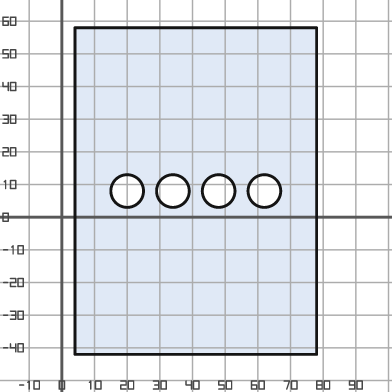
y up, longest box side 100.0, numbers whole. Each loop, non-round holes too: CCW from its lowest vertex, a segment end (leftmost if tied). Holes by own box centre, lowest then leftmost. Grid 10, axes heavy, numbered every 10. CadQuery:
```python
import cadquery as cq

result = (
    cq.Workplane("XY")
    .moveTo(4.0, -42.0)
    .lineTo(78.0, -42.0)
    .lineTo(78.0, 58.0)
    .lineTo(4.0, 58.0)
    .close()
    .moveTo(20.0, 8.0)
    .circle(5.0)
    .moveTo(34.0, 8.0)
    .circle(5.0)
    .moveTo(48.0, 8.0)
    .circle(5.0)
    .moveTo(62.0, 8.0)
    .circle(5.0)
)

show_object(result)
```